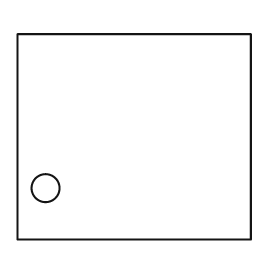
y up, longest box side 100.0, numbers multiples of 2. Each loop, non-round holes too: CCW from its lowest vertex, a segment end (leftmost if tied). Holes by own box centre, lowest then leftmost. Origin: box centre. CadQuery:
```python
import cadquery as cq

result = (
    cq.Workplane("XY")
    .moveTo(-50.0, -44.0)
    .lineTo(50.0, -44.0)
    .lineTo(50.0, 44.0)
    .lineTo(-50.0, 44.0)
    .close()
    .moveTo(-38.0, -22.0)
    .circle(6.0)
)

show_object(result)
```